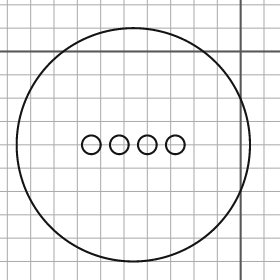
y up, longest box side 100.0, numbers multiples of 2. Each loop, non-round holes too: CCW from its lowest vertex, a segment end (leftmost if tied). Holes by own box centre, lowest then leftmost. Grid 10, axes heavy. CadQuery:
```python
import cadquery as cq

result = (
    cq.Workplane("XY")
    .moveTo(-46.0, -40.0)
    .circle(50.0)
    .moveTo(-64.0, -40.0)
    .circle(4.0)
    .moveTo(-52.0, -40.0)
    .circle(4.0)
    .moveTo(-40.0, -40.0)
    .circle(4.0)
    .moveTo(-28.0, -40.0)
    .circle(4.0)
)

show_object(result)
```